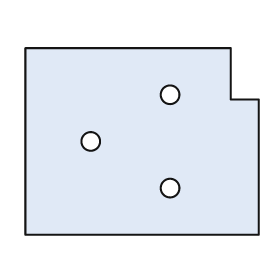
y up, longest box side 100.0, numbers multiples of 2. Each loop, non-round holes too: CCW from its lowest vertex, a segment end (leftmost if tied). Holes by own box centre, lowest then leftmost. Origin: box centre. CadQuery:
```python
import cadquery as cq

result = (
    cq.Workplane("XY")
    .moveTo(-50.0, -40.0)
    .lineTo(50.0, -40.0)
    .lineTo(50.0, 18.0)
    .lineTo(38.0, 18.0)
    .lineTo(38.0, 40.0)
    .lineTo(-50.0, 40.0)
    .close()
    .moveTo(12.0, -20.0)
    .circle(4.0)
    .moveTo(-22.0, 0.0)
    .circle(4.0)
    .moveTo(12.0, 20.0)
    .circle(4.0)
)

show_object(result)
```